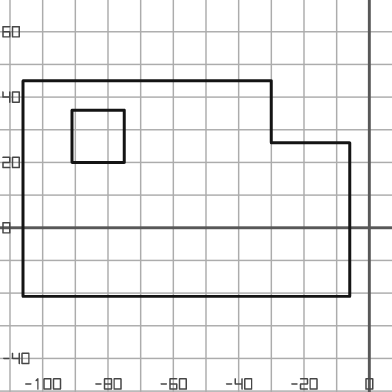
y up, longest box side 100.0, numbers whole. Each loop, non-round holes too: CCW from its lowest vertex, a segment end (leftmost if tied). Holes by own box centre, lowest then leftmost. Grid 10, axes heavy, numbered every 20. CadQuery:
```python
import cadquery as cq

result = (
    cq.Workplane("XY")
    .moveTo(-106.0, -21.0)
    .lineTo(-6.0, -21.0)
    .lineTo(-6.0, 26.0)
    .lineTo(-30.0, 26.0)
    .lineTo(-30.0, 45.0)
    .lineTo(-106.0, 45.0)
    .close()
    .moveTo(-91.0, 20.0)
    .lineTo(-75.0, 20.0)
    .lineTo(-75.0, 36.0)
    .lineTo(-91.0, 36.0)
    .close()
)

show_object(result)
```